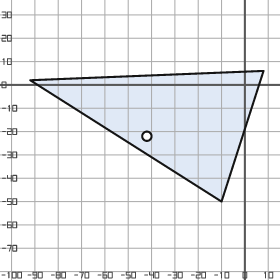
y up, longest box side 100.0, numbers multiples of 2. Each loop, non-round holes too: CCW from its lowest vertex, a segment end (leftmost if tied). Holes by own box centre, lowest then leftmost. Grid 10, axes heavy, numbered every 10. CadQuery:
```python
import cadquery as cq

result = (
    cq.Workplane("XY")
    .moveTo(-10.0, -50.0)
    .lineTo(8.0, 6.0)
    .lineTo(-92.0, 2.0)
    .close()
    .moveTo(-42.0, -22.0)
    .circle(2.0)
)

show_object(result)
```